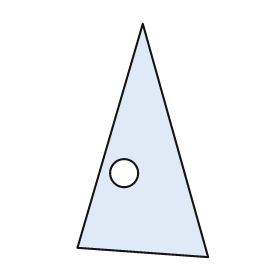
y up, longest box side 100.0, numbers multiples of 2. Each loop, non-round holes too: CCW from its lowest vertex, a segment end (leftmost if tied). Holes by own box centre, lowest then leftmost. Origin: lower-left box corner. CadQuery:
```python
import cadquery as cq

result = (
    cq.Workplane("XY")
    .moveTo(56.0, 0.0)
    .lineTo(28.0, 100.0)
    .lineTo(0.0, 4.0)
    .close()
    .moveTo(20.0, 36.0)
    .circle(6.0)
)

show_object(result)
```